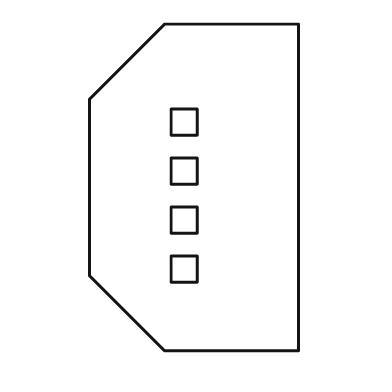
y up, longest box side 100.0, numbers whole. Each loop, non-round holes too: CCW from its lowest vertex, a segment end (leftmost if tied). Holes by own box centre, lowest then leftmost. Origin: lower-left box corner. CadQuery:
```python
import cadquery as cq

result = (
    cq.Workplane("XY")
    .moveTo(23.0, 0.0)
    .lineTo(64.0, 0.0)
    .lineTo(64.0, 100.0)
    .lineTo(23.0, 100.0)
    .lineTo(0.0, 77.0)
    .lineTo(0.0, 23.0)
    .close()
    .moveTo(25.0, 21.0)
    .lineTo(33.0, 21.0)
    .lineTo(33.0, 29.0)
    .lineTo(25.0, 29.0)
    .close()
    .moveTo(25.0, 36.0)
    .lineTo(33.0, 36.0)
    .lineTo(33.0, 44.0)
    .lineTo(25.0, 44.0)
    .close()
    .moveTo(25.0, 51.0)
    .lineTo(33.0, 51.0)
    .lineTo(33.0, 59.0)
    .lineTo(25.0, 59.0)
    .close()
    .moveTo(25.0, 66.0)
    .lineTo(33.0, 66.0)
    .lineTo(33.0, 74.0)
    .lineTo(25.0, 74.0)
    .close()
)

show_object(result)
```